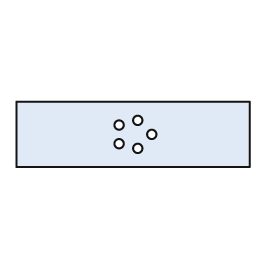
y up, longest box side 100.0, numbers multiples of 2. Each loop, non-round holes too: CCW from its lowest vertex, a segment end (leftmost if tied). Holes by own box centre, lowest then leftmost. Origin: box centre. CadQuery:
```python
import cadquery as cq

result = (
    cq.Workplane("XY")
    .moveTo(-50.0, -14.0)
    .lineTo(50.0, -14.0)
    .lineTo(50.0, 14.0)
    .lineTo(-50.0, 14.0)
    .close()
    .moveTo(2.0, -6.0)
    .circle(2.0)
    .moveTo(-6.0, -4.0)
    .circle(2.0)
    .moveTo(8.0, 0.0)
    .circle(2.0)
    .moveTo(-6.0, 4.0)
    .circle(2.0)
    .moveTo(2.0, 6.0)
    .circle(2.0)
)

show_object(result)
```